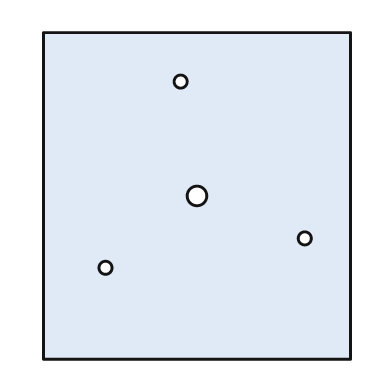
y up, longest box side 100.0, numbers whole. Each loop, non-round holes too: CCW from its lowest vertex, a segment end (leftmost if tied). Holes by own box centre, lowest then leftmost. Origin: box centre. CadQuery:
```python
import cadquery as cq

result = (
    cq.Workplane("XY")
    .moveTo(-47.0, -50.0)
    .lineTo(47.0, -50.0)
    .lineTo(47.0, 50.0)
    .lineTo(-47.0, 50.0)
    .close()
    .moveTo(-28.0, -22.0)
    .circle(2.0)
    .moveTo(33.0, -13.0)
    .circle(2.0)
    .moveTo(0.0, 0.0)
    .circle(3.0)
    .moveTo(-5.0, 35.0)
    .circle(2.0)
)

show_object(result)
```